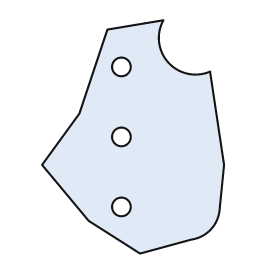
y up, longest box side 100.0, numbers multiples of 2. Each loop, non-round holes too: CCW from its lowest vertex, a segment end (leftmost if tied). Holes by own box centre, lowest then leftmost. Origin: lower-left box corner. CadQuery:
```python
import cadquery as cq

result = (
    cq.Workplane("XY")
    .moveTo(42.0, 0.0)
    .lineTo(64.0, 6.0)
    .threePointArc((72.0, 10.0), (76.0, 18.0))
    .lineTo(78.0, 38.0)
    .lineTo(72.0, 78.0)
    .threePointArc((54.0, 82.0), (52.0, 100.0))
    .lineTo(28.0, 96.0)
    .lineTo(16.0, 60.0)
    .lineTo(0.0, 38.0)
    .lineTo(20.0, 14.0)
    .close()
    .moveTo(34.0, 20.0)
    .circle(4.0)
    .moveTo(34.0, 50.0)
    .circle(4.0)
    .moveTo(34.0, 80.0)
    .circle(4.0)
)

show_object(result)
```